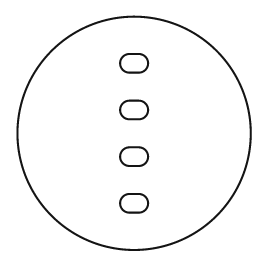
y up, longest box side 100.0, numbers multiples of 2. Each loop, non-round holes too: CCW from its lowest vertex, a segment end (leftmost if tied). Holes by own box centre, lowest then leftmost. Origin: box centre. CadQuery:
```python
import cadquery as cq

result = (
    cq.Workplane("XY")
    .moveTo(0.0, 0.0)
    .circle(50.0)
    .moveTo(-2.0, -34.0)
    .lineTo(2.0, -34.0)
    .threePointArc((6.0, -30.0), (2.0, -26.0))
    .lineTo(-2.0, -26.0)
    .threePointArc((-6.0, -30.0), (-2.0, -34.0))
    .close()
    .moveTo(-2.0, -14.0)
    .lineTo(2.0, -14.0)
    .threePointArc((6.0, -10.0), (2.0, -6.0))
    .lineTo(-2.0, -6.0)
    .threePointArc((-6.0, -10.0), (-2.0, -14.0))
    .close()
    .moveTo(-2.0, 6.0)
    .lineTo(2.0, 6.0)
    .threePointArc((6.0, 10.0), (2.0, 14.0))
    .lineTo(-2.0, 14.0)
    .threePointArc((-6.0, 10.0), (-2.0, 6.0))
    .close()
    .moveTo(-2.0, 26.0)
    .lineTo(2.0, 26.0)
    .threePointArc((6.0, 30.0), (2.0, 34.0))
    .lineTo(-2.0, 34.0)
    .threePointArc((-6.0, 30.0), (-2.0, 26.0))
    .close()
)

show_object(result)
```